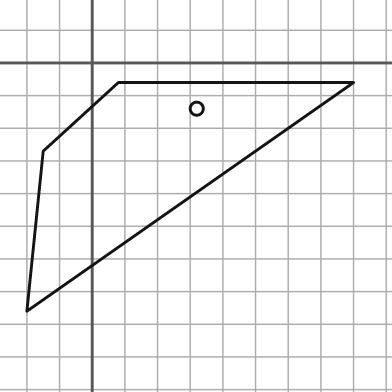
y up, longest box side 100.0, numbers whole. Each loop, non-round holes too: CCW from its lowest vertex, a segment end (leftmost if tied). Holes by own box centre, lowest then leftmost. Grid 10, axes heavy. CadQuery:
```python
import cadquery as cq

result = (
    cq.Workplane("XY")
    .moveTo(-20.0, -76.0)
    .lineTo(80.0, -6.0)
    .lineTo(8.0, -6.0)
    .lineTo(-15.0, -27.0)
    .close()
    .moveTo(32.0, -14.0)
    .circle(2.0)
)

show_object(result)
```